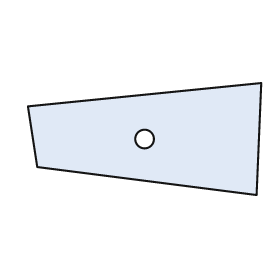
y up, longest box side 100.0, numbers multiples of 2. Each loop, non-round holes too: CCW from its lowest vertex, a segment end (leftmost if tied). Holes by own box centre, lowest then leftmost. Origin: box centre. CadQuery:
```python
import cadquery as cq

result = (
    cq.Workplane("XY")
    .moveTo(48.0, -24.0)
    .lineTo(50.0, 24.0)
    .lineTo(-50.0, 14.0)
    .lineTo(-46.0, -12.0)
    .close()
    .moveTo(0.0, 0.0)
    .circle(4.0)
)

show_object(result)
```